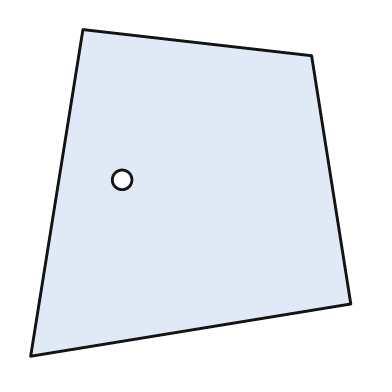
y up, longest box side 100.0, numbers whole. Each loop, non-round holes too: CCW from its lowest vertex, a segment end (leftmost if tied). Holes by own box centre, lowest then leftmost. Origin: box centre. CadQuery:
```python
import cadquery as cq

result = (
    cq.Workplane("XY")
    .moveTo(-49.0, -50.0)
    .lineTo(49.0, -34.0)
    .lineTo(37.0, 42.0)
    .lineTo(-33.0, 50.0)
    .close()
    .moveTo(-21.0, 4.0)
    .circle(3.0)
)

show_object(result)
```